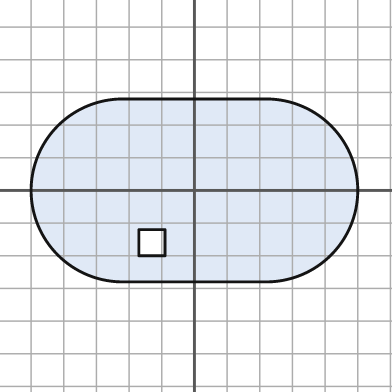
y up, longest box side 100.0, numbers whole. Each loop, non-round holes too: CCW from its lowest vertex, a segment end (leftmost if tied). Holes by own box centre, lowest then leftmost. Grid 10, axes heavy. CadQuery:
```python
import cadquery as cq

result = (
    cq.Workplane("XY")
    .moveTo(-22.0, -28.0)
    .lineTo(22.0, -28.0)
    .threePointArc((50.0, 0.0), (22.0, 28.0))
    .lineTo(-22.0, 28.0)
    .threePointArc((-50.0, 0.0), (-22.0, -28.0))
    .close()
    .moveTo(-17.0, -20.0)
    .lineTo(-9.0, -20.0)
    .lineTo(-9.0, -12.0)
    .lineTo(-17.0, -12.0)
    .close()
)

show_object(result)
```